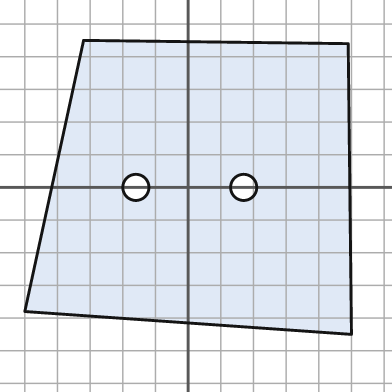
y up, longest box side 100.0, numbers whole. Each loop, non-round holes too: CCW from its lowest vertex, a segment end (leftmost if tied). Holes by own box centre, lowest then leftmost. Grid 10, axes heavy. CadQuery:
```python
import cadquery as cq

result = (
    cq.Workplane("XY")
    .moveTo(50.0, -45.0)
    .lineTo(49.0, 44.0)
    .lineTo(-32.0, 45.0)
    .lineTo(-50.0, -38.0)
    .close()
    .moveTo(-16.0, 0.0)
    .circle(4.0)
    .moveTo(17.0, 0.0)
    .circle(4.0)
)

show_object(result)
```